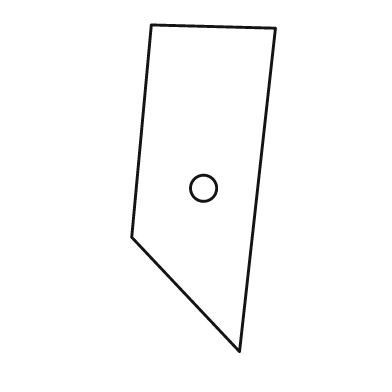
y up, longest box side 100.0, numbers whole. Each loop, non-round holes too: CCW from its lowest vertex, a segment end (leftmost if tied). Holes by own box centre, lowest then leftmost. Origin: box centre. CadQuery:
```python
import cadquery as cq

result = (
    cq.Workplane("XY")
    .moveTo(11.0, -50.0)
    .lineTo(22.0, 49.0)
    .lineTo(-16.0, 50.0)
    .lineTo(-22.0, -15.0)
    .close()
    .moveTo(0.0, 0.0)
    .circle(4.0)
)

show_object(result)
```